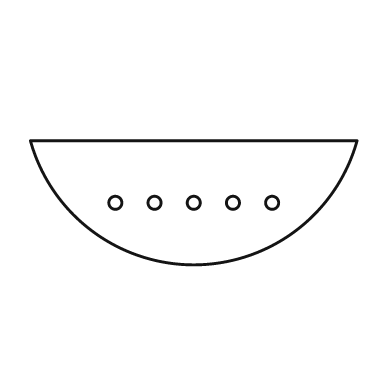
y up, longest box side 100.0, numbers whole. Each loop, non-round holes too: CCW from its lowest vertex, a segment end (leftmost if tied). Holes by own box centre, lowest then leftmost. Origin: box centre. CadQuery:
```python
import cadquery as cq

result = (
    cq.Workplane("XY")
    .moveTo(-50.0, 19.0)
    .threePointArc((0.0, -19.0), (50.0, 19.0))
    .close()
    .moveTo(-24.0, 0.0)
    .circle(2.0)
    .moveTo(-12.0, 0.0)
    .circle(2.0)
    .moveTo(0.0, 0.0)
    .circle(2.0)
    .moveTo(12.0, 0.0)
    .circle(2.0)
    .moveTo(24.0, 0.0)
    .circle(2.0)
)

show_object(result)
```